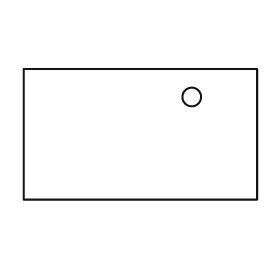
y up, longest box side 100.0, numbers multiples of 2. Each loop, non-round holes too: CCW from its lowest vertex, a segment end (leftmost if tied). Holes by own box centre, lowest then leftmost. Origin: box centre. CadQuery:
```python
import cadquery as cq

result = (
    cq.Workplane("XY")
    .moveTo(-50.0, -28.0)
    .lineTo(50.0, -28.0)
    .lineTo(50.0, 28.0)
    .lineTo(-50.0, 28.0)
    .close()
    .moveTo(22.0, 16.0)
    .circle(4.0)
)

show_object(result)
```